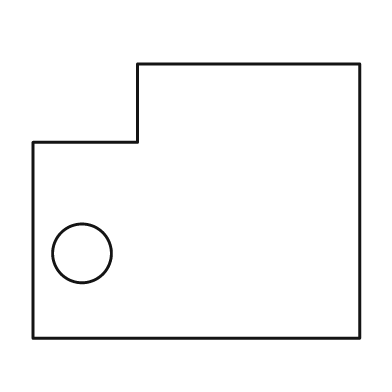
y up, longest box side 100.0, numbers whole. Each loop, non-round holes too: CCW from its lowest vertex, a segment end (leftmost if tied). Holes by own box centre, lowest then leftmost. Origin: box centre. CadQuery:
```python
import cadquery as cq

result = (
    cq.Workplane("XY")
    .moveTo(-50.0, -42.0)
    .lineTo(50.0, -42.0)
    .lineTo(50.0, 42.0)
    .lineTo(-18.0, 42.0)
    .lineTo(-18.0, 18.0)
    .lineTo(-50.0, 18.0)
    .close()
    .moveTo(-35.0, -16.0)
    .circle(9.0)
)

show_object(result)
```